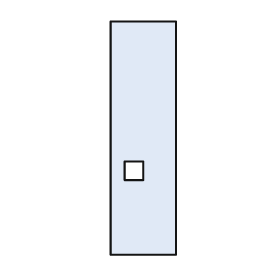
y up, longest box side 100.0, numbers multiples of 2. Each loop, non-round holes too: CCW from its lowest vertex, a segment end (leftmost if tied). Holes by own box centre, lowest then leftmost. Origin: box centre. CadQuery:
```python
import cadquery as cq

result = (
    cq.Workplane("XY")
    .moveTo(-14.0, -50.0)
    .lineTo(14.0, -50.0)
    .lineTo(14.0, 50.0)
    .lineTo(-14.0, 50.0)
    .close()
    .moveTo(-8.0, -18.0)
    .lineTo(0.0, -18.0)
    .lineTo(0.0, -10.0)
    .lineTo(-8.0, -10.0)
    .close()
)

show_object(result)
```